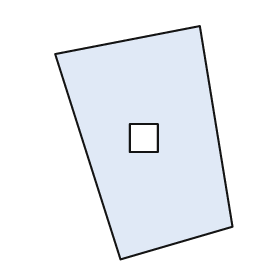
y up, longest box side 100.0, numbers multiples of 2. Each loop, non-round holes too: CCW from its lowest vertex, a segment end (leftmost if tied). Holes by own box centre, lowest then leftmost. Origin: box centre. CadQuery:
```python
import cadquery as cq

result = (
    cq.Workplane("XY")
    .moveTo(-10.0, -50.0)
    .lineTo(38.0, -36.0)
    .lineTo(24.0, 50.0)
    .lineTo(-38.0, 38.0)
    .close()
    .moveTo(-6.0, -4.0)
    .lineTo(6.0, -4.0)
    .lineTo(6.0, 8.0)
    .lineTo(-6.0, 8.0)
    .close()
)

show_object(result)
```